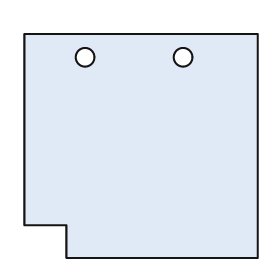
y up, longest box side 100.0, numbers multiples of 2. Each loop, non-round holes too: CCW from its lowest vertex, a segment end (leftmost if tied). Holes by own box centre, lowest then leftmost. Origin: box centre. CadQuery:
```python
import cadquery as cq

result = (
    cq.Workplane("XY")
    .moveTo(-32.0, -48.0)
    .lineTo(50.0, -48.0)
    .lineTo(50.0, 48.0)
    .lineTo(-50.0, 48.0)
    .lineTo(-50.0, -34.0)
    .lineTo(-32.0, -34.0)
    .close()
    .moveTo(-24.0, 38.0)
    .circle(4.0)
    .moveTo(18.0, 38.0)
    .circle(4.0)
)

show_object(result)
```